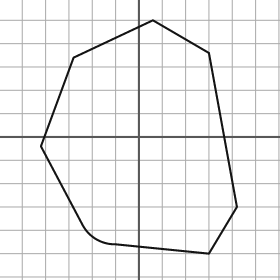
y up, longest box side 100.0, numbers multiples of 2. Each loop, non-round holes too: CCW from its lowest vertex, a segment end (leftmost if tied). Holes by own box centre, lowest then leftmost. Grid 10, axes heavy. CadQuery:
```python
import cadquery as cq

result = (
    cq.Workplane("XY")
    .moveTo(30.0, -50.0)
    .lineTo(42.0, -30.0)
    .lineTo(30.0, 36.0)
    .lineTo(6.0, 50.0)
    .lineTo(-28.0, 34.0)
    .lineTo(-42.0, -4.0)
    .lineTo(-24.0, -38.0)
    .threePointArc((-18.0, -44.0), (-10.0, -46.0))
    .close()
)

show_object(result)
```